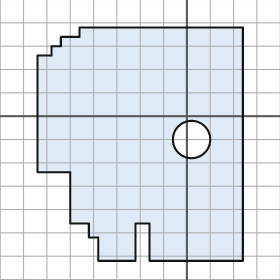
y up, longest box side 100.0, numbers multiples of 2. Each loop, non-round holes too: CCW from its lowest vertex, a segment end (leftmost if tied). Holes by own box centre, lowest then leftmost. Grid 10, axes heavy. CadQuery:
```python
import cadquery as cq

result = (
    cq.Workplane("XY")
    .moveTo(-38.0, -62.0)
    .lineTo(-22.0, -62.0)
    .lineTo(-22.0, -46.0)
    .lineTo(-16.0, -46.0)
    .lineTo(-16.0, -62.0)
    .lineTo(24.0, -62.0)
    .lineTo(24.0, 38.0)
    .lineTo(-46.0, 38.0)
    .lineTo(-46.0, 34.0)
    .lineTo(-54.0, 34.0)
    .lineTo(-54.0, 30.0)
    .lineTo(-58.0, 30.0)
    .lineTo(-58.0, 26.0)
    .lineTo(-64.0, 26.0)
    .lineTo(-64.0, -24.0)
    .lineTo(-50.0, -24.0)
    .lineTo(-50.0, -46.0)
    .lineTo(-42.0, -46.0)
    .lineTo(-42.0, -52.0)
    .lineTo(-38.0, -52.0)
    .close()
    .moveTo(2.0, -10.0)
    .circle(8.0)
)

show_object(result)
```